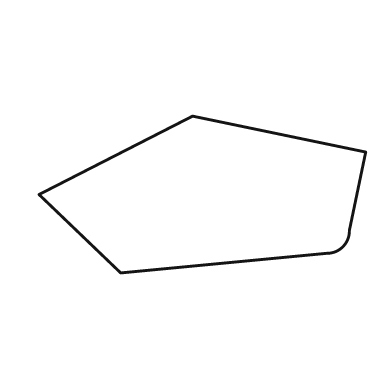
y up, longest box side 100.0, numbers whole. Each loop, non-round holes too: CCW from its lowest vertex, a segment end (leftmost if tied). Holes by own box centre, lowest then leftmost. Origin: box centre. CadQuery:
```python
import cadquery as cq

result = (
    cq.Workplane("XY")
    .moveTo(-25.0, -24.0)
    .lineTo(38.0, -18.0)
    .threePointArc((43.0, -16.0), (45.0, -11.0))
    .lineTo(50.0, 13.0)
    .lineTo(-3.0, 24.0)
    .lineTo(-50.0, 0.0)
    .close()
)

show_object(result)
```